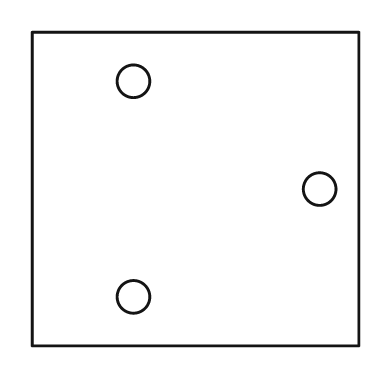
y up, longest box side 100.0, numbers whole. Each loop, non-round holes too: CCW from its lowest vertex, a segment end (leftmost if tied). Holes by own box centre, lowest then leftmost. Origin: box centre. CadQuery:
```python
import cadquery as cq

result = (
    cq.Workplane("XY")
    .moveTo(-50.0, -48.0)
    .lineTo(50.0, -48.0)
    .lineTo(50.0, 48.0)
    .lineTo(-50.0, 48.0)
    .close()
    .moveTo(-19.0, -33.0)
    .circle(5.0)
    .moveTo(38.0, 0.0)
    .circle(5.0)
    .moveTo(-19.0, 33.0)
    .circle(5.0)
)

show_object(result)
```